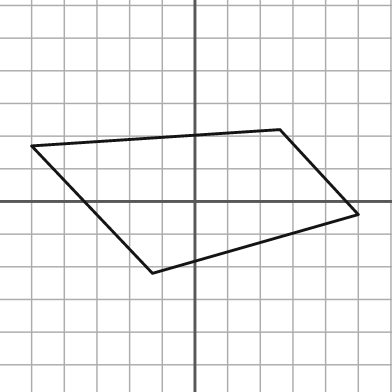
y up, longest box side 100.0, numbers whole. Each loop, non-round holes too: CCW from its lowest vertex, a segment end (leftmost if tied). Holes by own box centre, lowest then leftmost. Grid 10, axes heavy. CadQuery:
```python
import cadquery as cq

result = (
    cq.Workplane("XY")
    .moveTo(-13.0, -22.0)
    .lineTo(50.0, -4.0)
    .lineTo(26.0, 22.0)
    .lineTo(-50.0, 17.0)
    .close()
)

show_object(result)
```